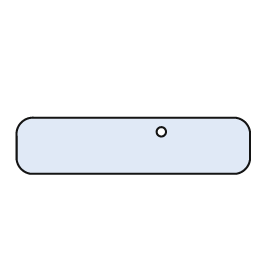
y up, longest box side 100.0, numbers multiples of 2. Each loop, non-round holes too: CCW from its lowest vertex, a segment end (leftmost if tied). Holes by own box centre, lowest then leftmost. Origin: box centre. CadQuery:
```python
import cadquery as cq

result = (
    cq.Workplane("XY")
    .moveTo(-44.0, -12.0)
    .lineTo(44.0, -12.0)
    .threePointArc((48.0, -10.0), (50.0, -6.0))
    .lineTo(50.0, 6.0)
    .threePointArc((48.0, 10.0), (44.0, 12.0))
    .lineTo(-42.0, 12.0)
    .threePointArc((-48.0, 10.0), (-50.0, 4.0))
    .lineTo(-50.0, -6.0)
    .threePointArc((-48.0, -10.0), (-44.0, -12.0))
    .close()
    .moveTo(12.0, 6.0)
    .circle(2.0)
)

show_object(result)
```